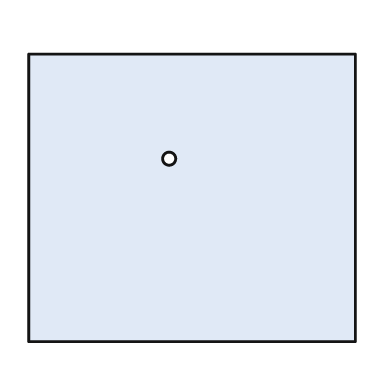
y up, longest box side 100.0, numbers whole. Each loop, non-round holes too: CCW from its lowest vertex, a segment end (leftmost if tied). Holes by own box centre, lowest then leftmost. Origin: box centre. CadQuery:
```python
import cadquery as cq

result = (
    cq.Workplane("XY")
    .moveTo(-50.0, -44.0)
    .lineTo(50.0, -44.0)
    .lineTo(50.0, 44.0)
    .lineTo(-50.0, 44.0)
    .close()
    .moveTo(-7.0, 12.0)
    .circle(2.0)
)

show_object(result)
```